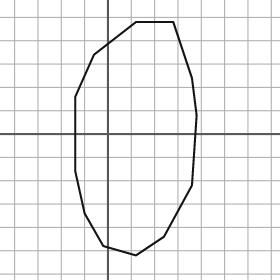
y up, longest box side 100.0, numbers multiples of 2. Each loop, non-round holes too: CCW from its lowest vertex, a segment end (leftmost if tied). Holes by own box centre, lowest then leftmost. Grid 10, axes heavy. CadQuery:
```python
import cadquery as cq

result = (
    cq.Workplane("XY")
    .moveTo(12.0, -52.0)
    .lineTo(24.0, -44.0)
    .lineTo(36.0, -22.0)
    .lineTo(38.0, 8.0)
    .lineTo(36.0, 24.0)
    .lineTo(28.0, 48.0)
    .lineTo(12.0, 48.0)
    .lineTo(-6.0, 34.0)
    .lineTo(-14.0, 16.0)
    .lineTo(-14.0, -16.0)
    .lineTo(-10.0, -34.0)
    .lineTo(-2.0, -48.0)
    .close()
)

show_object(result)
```